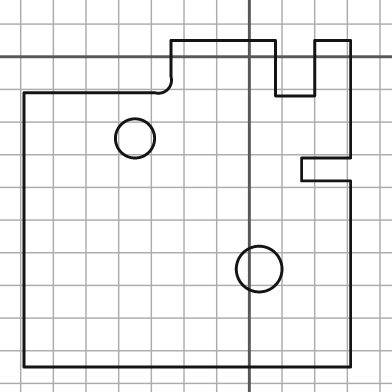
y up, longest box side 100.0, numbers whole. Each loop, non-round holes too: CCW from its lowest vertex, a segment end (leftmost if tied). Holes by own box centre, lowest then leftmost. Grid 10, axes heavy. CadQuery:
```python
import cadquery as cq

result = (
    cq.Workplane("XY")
    .moveTo(-69.0, -95.0)
    .lineTo(31.0, -95.0)
    .lineTo(31.0, -38.0)
    .lineTo(16.0, -38.0)
    .lineTo(16.0, -31.0)
    .lineTo(31.0, -31.0)
    .lineTo(31.0, 5.0)
    .lineTo(20.0, 5.0)
    .lineTo(20.0, -12.0)
    .lineTo(8.0, -12.0)
    .lineTo(8.0, 5.0)
    .lineTo(-24.0, 5.0)
    .lineTo(-24.0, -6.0)
    .threePointArc((-25.0, -10.0), (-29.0, -11.0))
    .lineTo(-69.0, -11.0)
    .close()
    .moveTo(3.0, -65.0)
    .circle(7.0)
    .moveTo(-35.0, -25.0)
    .circle(6.0)
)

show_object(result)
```